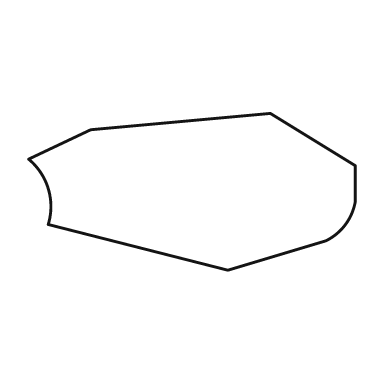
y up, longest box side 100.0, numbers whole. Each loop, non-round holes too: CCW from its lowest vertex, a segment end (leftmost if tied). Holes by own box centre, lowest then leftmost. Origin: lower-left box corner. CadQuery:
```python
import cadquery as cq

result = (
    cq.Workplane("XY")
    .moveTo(61.0, 0.0)
    .lineTo(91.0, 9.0)
    .threePointArc((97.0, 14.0), (100.0, 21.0))
    .lineTo(100.0, 32.0)
    .lineTo(74.0, 48.0)
    .lineTo(19.0, 43.0)
    .lineTo(0.0, 34.0)
    .threePointArc((6.0, 25.0), (6.0, 14.0))
    .close()
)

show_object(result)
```